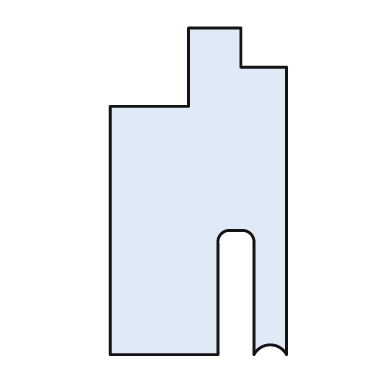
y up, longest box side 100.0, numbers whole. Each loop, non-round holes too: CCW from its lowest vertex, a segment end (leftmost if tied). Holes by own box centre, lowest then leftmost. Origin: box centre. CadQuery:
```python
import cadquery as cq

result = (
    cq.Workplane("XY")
    .moveTo(-27.0, -50.0)
    .lineTo(6.0, -50.0)
    .lineTo(6.0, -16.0)
    .threePointArc((7.0, -13.0), (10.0, -12.0))
    .lineTo(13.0, -12.0)
    .threePointArc((16.0, -13.0), (17.0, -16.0))
    .lineTo(17.0, -50.0)
    .threePointArc((22.0, -47.0), (27.0, -50.0))
    .lineTo(27.0, 38.0)
    .lineTo(13.0, 38.0)
    .lineTo(13.0, 50.0)
    .lineTo(-3.0, 50.0)
    .lineTo(-3.0, 26.0)
    .lineTo(-27.0, 26.0)
    .close()
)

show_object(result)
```